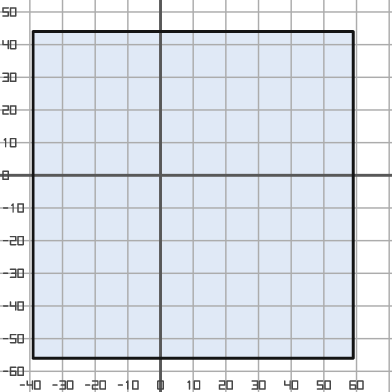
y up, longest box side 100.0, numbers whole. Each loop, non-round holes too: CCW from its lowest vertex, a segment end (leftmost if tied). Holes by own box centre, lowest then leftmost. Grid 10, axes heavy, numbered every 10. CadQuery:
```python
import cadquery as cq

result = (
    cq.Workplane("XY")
    .moveTo(-39.0, -56.0)
    .lineTo(59.0, -56.0)
    .lineTo(59.0, 44.0)
    .lineTo(-39.0, 44.0)
    .close()
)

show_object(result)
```